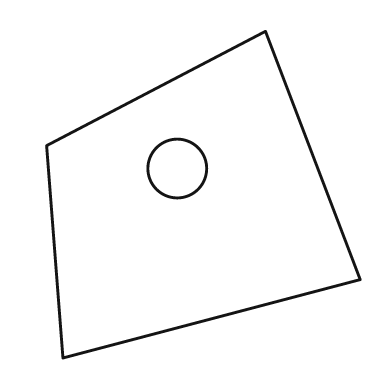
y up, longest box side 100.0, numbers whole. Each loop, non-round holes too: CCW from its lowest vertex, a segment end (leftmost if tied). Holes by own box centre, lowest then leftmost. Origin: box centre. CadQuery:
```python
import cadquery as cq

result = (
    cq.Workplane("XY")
    .moveTo(-43.0, -50.0)
    .lineTo(48.0, -26.0)
    .lineTo(19.0, 50.0)
    .lineTo(-48.0, 15.0)
    .close()
    .moveTo(-8.0, 8.0)
    .circle(9.0)
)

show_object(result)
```